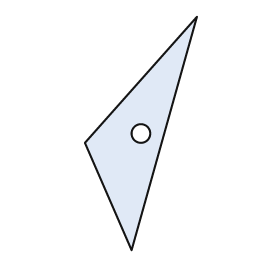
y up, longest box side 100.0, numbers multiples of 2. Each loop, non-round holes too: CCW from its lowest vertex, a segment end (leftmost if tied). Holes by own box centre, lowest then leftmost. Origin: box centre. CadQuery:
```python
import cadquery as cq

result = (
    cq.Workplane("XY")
    .moveTo(-4.0, -50.0)
    .lineTo(24.0, 50.0)
    .lineTo(-24.0, -4.0)
    .close()
    .moveTo(0.0, 0.0)
    .circle(4.0)
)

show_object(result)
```